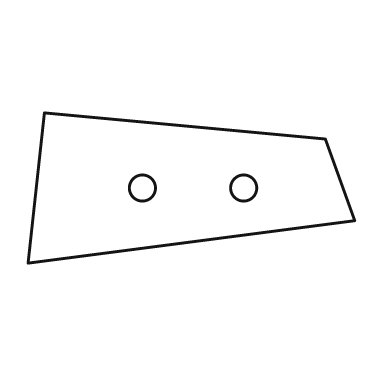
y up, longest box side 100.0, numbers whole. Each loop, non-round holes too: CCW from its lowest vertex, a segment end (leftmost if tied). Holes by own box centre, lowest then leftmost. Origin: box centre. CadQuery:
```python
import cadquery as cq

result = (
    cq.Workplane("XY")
    .moveTo(-50.0, -23.0)
    .lineTo(50.0, -10.0)
    .lineTo(41.0, 15.0)
    .lineTo(-45.0, 23.0)
    .close()
    .moveTo(-15.0, 0.0)
    .circle(4.0)
    .moveTo(16.0, 0.0)
    .circle(4.0)
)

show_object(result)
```